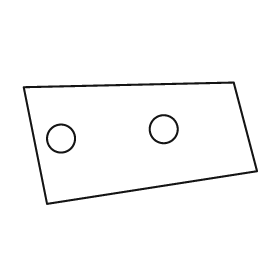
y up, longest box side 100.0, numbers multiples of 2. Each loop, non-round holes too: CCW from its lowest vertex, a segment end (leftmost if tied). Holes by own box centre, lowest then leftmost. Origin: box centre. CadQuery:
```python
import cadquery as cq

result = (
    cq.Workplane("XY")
    .moveTo(-40.0, -26.0)
    .lineTo(50.0, -12.0)
    .lineTo(40.0, 26.0)
    .lineTo(-50.0, 24.0)
    .close()
    .moveTo(-34.0, 2.0)
    .circle(6.0)
    .moveTo(10.0, 6.0)
    .circle(6.0)
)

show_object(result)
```